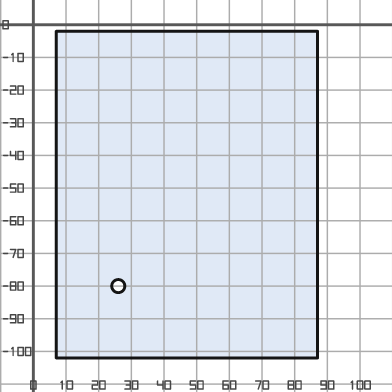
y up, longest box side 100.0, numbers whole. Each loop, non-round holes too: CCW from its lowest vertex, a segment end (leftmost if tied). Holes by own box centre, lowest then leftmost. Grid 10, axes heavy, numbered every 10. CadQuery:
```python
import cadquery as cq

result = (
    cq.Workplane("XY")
    .moveTo(7.0, -102.0)
    .lineTo(87.0, -102.0)
    .lineTo(87.0, -2.0)
    .lineTo(7.0, -2.0)
    .close()
    .moveTo(26.0, -80.0)
    .circle(2.0)
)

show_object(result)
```